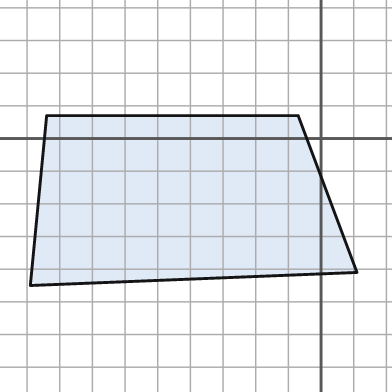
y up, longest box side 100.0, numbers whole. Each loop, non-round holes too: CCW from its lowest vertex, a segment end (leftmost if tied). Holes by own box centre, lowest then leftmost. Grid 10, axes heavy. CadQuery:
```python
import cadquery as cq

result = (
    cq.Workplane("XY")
    .moveTo(-89.0, -45.0)
    .lineTo(11.0, -41.0)
    .lineTo(-7.0, 7.0)
    .lineTo(-84.0, 7.0)
    .close()
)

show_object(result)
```